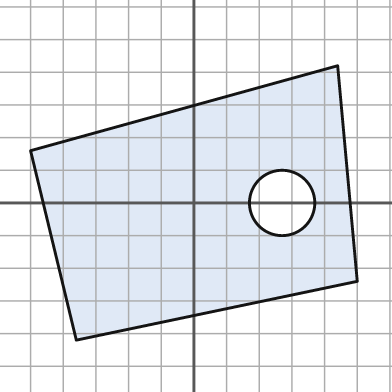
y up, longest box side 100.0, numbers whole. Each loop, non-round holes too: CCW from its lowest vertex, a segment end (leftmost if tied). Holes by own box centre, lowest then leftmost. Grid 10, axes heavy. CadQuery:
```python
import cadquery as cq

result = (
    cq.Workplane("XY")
    .moveTo(-36.0, -42.0)
    .lineTo(50.0, -24.0)
    .lineTo(44.0, 42.0)
    .lineTo(-50.0, 16.0)
    .close()
    .moveTo(27.0, 0.0)
    .circle(10.0)
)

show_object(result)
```